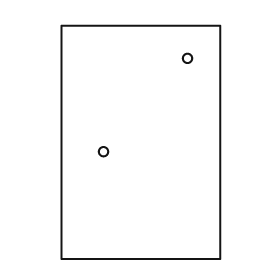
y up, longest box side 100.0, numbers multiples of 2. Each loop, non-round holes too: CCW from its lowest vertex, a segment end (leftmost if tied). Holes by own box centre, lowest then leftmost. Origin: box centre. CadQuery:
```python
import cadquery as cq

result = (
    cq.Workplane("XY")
    .moveTo(-34.0, -50.0)
    .lineTo(34.0, -50.0)
    .lineTo(34.0, 50.0)
    .lineTo(-34.0, 50.0)
    .close()
    .moveTo(-16.0, -4.0)
    .circle(2.0)
    .moveTo(20.0, 36.0)
    .circle(2.0)
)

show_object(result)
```